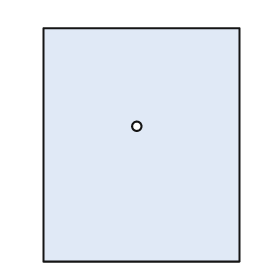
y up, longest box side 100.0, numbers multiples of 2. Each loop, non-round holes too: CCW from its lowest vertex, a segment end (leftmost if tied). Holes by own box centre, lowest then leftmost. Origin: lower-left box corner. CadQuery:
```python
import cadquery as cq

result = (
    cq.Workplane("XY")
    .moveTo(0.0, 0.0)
    .lineTo(84.0, 0.0)
    .lineTo(84.0, 100.0)
    .lineTo(0.0, 100.0)
    .close()
    .moveTo(40.0, 58.0)
    .circle(2.0)
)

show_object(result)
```